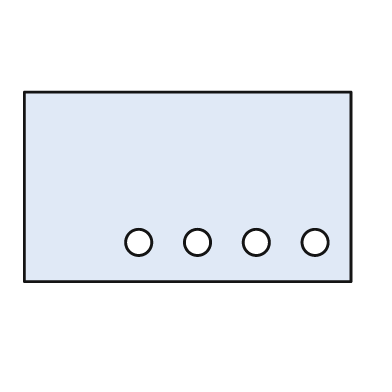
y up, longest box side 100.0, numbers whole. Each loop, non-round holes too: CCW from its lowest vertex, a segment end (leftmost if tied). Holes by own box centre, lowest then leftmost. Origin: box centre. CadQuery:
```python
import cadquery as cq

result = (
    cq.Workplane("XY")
    .moveTo(-50.0, -29.0)
    .lineTo(50.0, -29.0)
    .lineTo(50.0, 29.0)
    .lineTo(-50.0, 29.0)
    .close()
    .moveTo(-15.0, -17.0)
    .circle(4.0)
    .moveTo(3.0, -17.0)
    .circle(4.0)
    .moveTo(21.0, -17.0)
    .circle(4.0)
    .moveTo(39.0, -17.0)
    .circle(4.0)
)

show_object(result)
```